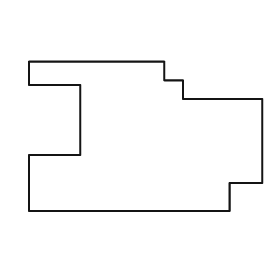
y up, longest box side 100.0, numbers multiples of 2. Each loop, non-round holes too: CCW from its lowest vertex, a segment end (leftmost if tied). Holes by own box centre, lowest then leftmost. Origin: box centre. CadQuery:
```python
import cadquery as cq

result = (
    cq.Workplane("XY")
    .moveTo(-50.0, -32.0)
    .lineTo(36.0, -32.0)
    .lineTo(36.0, -20.0)
    .lineTo(50.0, -20.0)
    .lineTo(50.0, 16.0)
    .lineTo(16.0, 16.0)
    .lineTo(16.0, 24.0)
    .lineTo(8.0, 24.0)
    .lineTo(8.0, 32.0)
    .lineTo(-50.0, 32.0)
    .lineTo(-50.0, 22.0)
    .lineTo(-28.0, 22.0)
    .lineTo(-28.0, -8.0)
    .lineTo(-50.0, -8.0)
    .close()
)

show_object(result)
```